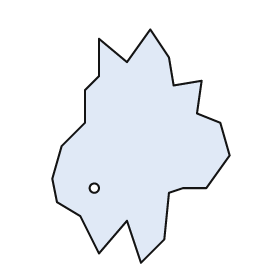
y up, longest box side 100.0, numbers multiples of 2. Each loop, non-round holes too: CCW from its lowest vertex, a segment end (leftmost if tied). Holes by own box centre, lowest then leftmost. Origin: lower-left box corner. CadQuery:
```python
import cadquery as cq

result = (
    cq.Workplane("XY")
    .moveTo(38.0, 0.0)
    .lineTo(48.0, 10.0)
    .lineTo(50.0, 30.0)
    .lineTo(56.0, 32.0)
    .lineTo(66.0, 32.0)
    .lineTo(76.0, 46.0)
    .lineTo(72.0, 60.0)
    .lineTo(62.0, 64.0)
    .lineTo(64.0, 78.0)
    .lineTo(52.0, 76.0)
    .lineTo(50.0, 88.0)
    .lineTo(42.0, 100.0)
    .lineTo(32.0, 86.0)
    .lineTo(20.0, 96.0)
    .lineTo(20.0, 80.0)
    .lineTo(14.0, 74.0)
    .lineTo(14.0, 60.0)
    .lineTo(4.0, 50.0)
    .lineTo(0.0, 36.0)
    .lineTo(2.0, 26.0)
    .lineTo(12.0, 20.0)
    .lineTo(20.0, 4.0)
    .lineTo(32.0, 18.0)
    .close()
    .moveTo(18.0, 32.0)
    .circle(2.0)
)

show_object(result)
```